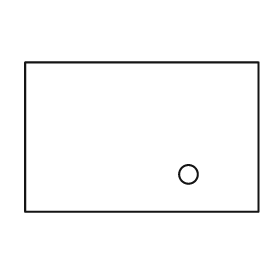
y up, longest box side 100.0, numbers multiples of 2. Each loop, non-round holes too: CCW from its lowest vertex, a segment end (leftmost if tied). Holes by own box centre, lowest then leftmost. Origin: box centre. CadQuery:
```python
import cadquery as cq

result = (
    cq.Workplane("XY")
    .moveTo(-50.0, -32.0)
    .lineTo(50.0, -32.0)
    .lineTo(50.0, 32.0)
    .lineTo(-50.0, 32.0)
    .close()
    .moveTo(20.0, -16.0)
    .circle(4.0)
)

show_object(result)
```